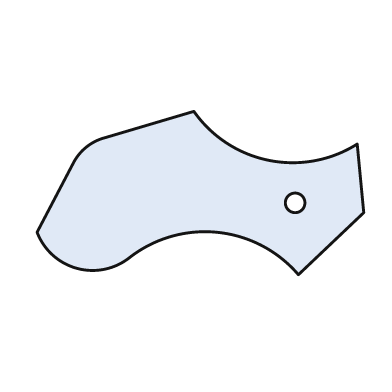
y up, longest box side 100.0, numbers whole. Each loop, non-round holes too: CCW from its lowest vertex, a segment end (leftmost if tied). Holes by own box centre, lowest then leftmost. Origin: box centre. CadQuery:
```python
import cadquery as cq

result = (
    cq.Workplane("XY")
    .moveTo(30.0, -25.0)
    .lineTo(50.0, -6.0)
    .lineTo(48.0, 15.0)
    .threePointArc((21.0, 10.0), (-2.0, 25.0))
    .lineTo(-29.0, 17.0)
    .threePointArc((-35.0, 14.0), (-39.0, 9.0))
    .lineTo(-50.0, -12.0)
    .threePointArc((-38.0, -23.0), (-22.0, -20.0))
    .threePointArc((5.0, -12.0), (30.0, -25.0))
    .close()
    .moveTo(29.0, -3.0)
    .circle(3.0)
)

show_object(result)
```